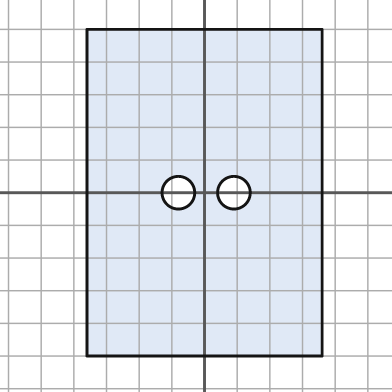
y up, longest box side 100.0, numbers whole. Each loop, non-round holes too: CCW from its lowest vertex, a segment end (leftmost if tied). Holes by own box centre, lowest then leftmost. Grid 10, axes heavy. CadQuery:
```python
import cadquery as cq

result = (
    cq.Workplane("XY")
    .moveTo(-36.0, -50.0)
    .lineTo(36.0, -50.0)
    .lineTo(36.0, 50.0)
    .lineTo(-36.0, 50.0)
    .close()
    .moveTo(-8.0, 0.0)
    .circle(5.0)
    .moveTo(9.0, 0.0)
    .circle(5.0)
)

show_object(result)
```